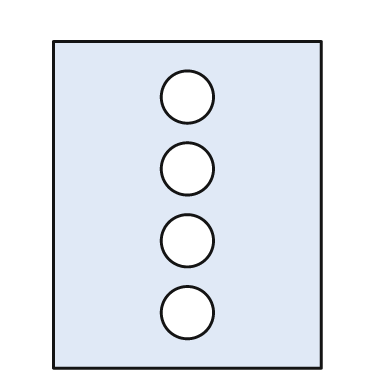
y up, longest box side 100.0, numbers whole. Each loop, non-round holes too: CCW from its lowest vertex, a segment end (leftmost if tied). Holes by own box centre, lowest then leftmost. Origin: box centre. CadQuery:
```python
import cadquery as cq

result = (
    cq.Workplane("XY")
    .moveTo(-41.0, -50.0)
    .lineTo(41.0, -50.0)
    .lineTo(41.0, 50.0)
    .lineTo(-41.0, 50.0)
    .close()
    .moveTo(0.0, -33.0)
    .circle(8.0)
    .moveTo(0.0, -11.0)
    .circle(8.0)
    .moveTo(0.0, 11.0)
    .circle(8.0)
    .moveTo(0.0, 33.0)
    .circle(8.0)
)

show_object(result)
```